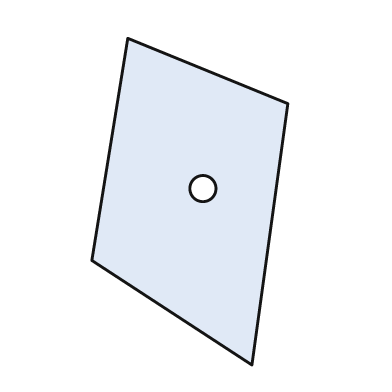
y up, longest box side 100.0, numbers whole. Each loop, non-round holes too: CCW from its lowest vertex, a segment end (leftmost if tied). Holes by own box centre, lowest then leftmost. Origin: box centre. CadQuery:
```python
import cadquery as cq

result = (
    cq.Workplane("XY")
    .moveTo(19.0, -50.0)
    .lineTo(30.0, 30.0)
    .lineTo(-19.0, 50.0)
    .lineTo(-30.0, -18.0)
    .close()
    .moveTo(4.0, 4.0)
    .circle(4.0)
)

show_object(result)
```